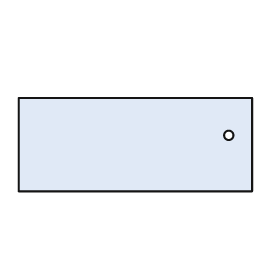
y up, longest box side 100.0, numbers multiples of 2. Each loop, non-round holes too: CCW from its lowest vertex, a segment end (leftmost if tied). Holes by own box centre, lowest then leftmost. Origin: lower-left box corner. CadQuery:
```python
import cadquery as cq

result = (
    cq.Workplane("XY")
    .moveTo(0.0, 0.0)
    .lineTo(100.0, 0.0)
    .lineTo(100.0, 40.0)
    .lineTo(0.0, 40.0)
    .close()
    .moveTo(90.0, 24.0)
    .circle(2.0)
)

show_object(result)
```